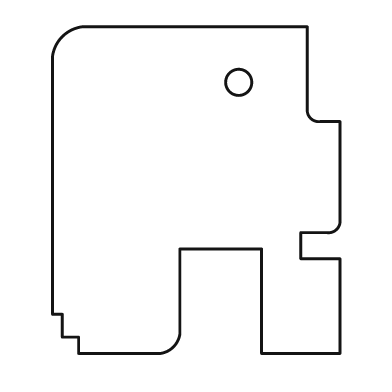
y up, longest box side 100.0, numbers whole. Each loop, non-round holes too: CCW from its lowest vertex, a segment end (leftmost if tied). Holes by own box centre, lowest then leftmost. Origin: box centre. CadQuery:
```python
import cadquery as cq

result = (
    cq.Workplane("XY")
    .moveTo(-36.0, -50.0)
    .lineTo(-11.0, -50.0)
    .threePointArc((-7.0, -48.0), (-5.0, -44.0))
    .lineTo(-5.0, -18.0)
    .lineTo(20.0, -18.0)
    .lineTo(20.0, -50.0)
    .lineTo(44.0, -50.0)
    .lineTo(44.0, -21.0)
    .lineTo(32.0, -21.0)
    .lineTo(32.0, -13.0)
    .lineTo(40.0, -13.0)
    .threePointArc((43.0, -12.0), (44.0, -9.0))
    .lineTo(44.0, 21.0)
    .lineTo(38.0, 21.0)
    .threePointArc((35.0, 22.0), (34.0, 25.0))
    .lineTo(34.0, 50.0)
    .lineTo(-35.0, 50.0)
    .threePointArc((-41.0, 47.0), (-44.0, 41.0))
    .lineTo(-44.0, -38.0)
    .lineTo(-41.0, -38.0)
    .lineTo(-41.0, -45.0)
    .lineTo(-36.0, -45.0)
    .close()
    .moveTo(13.0, 33.0)
    .circle(4.0)
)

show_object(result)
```